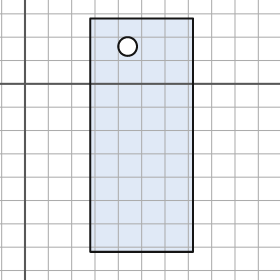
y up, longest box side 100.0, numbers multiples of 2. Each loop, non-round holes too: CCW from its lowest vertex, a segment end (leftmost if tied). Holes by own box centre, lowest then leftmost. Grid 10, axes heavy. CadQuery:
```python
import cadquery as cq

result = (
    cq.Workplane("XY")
    .moveTo(28.0, -72.0)
    .lineTo(72.0, -72.0)
    .lineTo(72.0, 28.0)
    .lineTo(28.0, 28.0)
    .close()
    .moveTo(44.0, 16.0)
    .circle(4.0)
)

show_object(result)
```